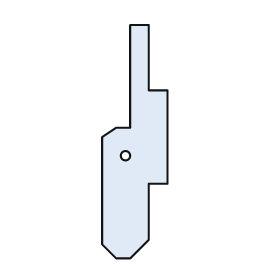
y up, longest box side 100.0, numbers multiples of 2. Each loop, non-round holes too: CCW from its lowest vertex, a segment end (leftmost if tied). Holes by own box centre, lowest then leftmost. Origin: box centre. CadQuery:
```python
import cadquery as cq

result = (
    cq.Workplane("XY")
    .moveTo(-8.0, -50.0)
    .lineTo(-2.0, -50.0)
    .lineTo(6.0, -42.0)
    .lineTo(6.0, -18.0)
    .lineTo(14.0, -18.0)
    .lineTo(14.0, 22.0)
    .lineTo(6.0, 22.0)
    .lineTo(6.0, 50.0)
    .lineTo(-2.0, 50.0)
    .lineTo(-2.0, 6.0)
    .lineTo(-8.0, 6.0)
    .lineTo(-14.0, 2.0)
    .lineTo(-14.0, -44.0)
    .close()
    .moveTo(-4.0, -6.0)
    .circle(2.0)
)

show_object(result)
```